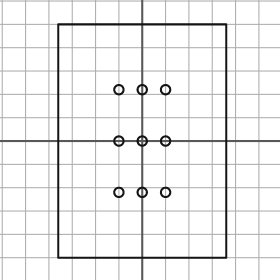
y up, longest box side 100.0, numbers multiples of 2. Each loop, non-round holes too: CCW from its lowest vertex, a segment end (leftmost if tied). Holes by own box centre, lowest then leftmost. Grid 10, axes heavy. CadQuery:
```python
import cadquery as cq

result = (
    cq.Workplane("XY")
    .moveTo(-36.0, -50.0)
    .lineTo(36.0, -50.0)
    .lineTo(36.0, 50.0)
    .lineTo(-36.0, 50.0)
    .close()
    .moveTo(-10.0, -22.0)
    .circle(2.0)
    .moveTo(0.0, -22.0)
    .circle(2.0)
    .moveTo(10.0, -22.0)
    .circle(2.0)
    .moveTo(-10.0, 0.0)
    .circle(2.0)
    .moveTo(0.0, 0.0)
    .circle(2.0)
    .moveTo(10.0, 0.0)
    .circle(2.0)
    .moveTo(-10.0, 22.0)
    .circle(2.0)
    .moveTo(0.0, 22.0)
    .circle(2.0)
    .moveTo(10.0, 22.0)
    .circle(2.0)
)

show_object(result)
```